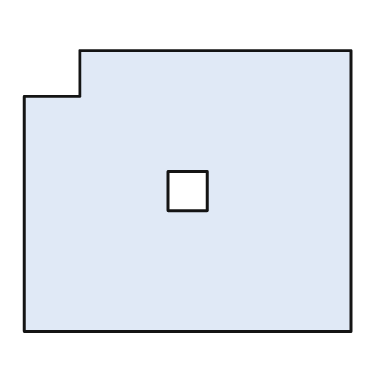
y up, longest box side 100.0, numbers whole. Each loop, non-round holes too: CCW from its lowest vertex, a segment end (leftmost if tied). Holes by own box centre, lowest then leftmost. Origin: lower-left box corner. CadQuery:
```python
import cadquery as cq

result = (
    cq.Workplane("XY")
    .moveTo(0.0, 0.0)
    .lineTo(100.0, 0.0)
    .lineTo(100.0, 86.0)
    .lineTo(17.0, 86.0)
    .lineTo(17.0, 72.0)
    .lineTo(0.0, 72.0)
    .close()
    .moveTo(44.0, 37.0)
    .lineTo(56.0, 37.0)
    .lineTo(56.0, 49.0)
    .lineTo(44.0, 49.0)
    .close()
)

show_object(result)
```